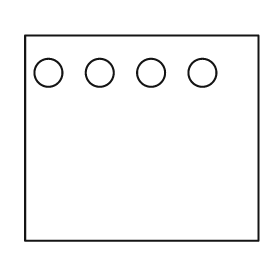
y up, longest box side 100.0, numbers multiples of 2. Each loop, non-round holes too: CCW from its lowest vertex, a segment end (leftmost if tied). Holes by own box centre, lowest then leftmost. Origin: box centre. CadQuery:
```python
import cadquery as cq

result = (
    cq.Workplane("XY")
    .moveTo(-50.0, -44.0)
    .lineTo(50.0, -44.0)
    .lineTo(50.0, 44.0)
    .lineTo(-50.0, 44.0)
    .close()
    .moveTo(-40.0, 28.0)
    .circle(6.0)
    .moveTo(-18.0, 28.0)
    .circle(6.0)
    .moveTo(4.0, 28.0)
    .circle(6.0)
    .moveTo(26.0, 28.0)
    .circle(6.0)
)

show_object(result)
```